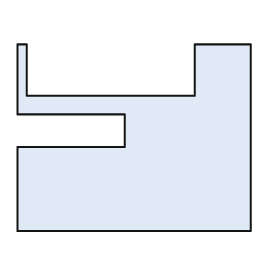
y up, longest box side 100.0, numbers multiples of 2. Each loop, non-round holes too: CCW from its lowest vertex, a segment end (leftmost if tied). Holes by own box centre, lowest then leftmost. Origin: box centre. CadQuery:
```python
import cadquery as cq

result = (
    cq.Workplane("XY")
    .moveTo(-50.0, -40.0)
    .lineTo(50.0, -40.0)
    .lineTo(50.0, 40.0)
    .lineTo(26.0, 40.0)
    .lineTo(26.0, 18.0)
    .lineTo(-46.0, 18.0)
    .lineTo(-46.0, 40.0)
    .lineTo(-50.0, 40.0)
    .lineTo(-50.0, 10.0)
    .lineTo(-4.0, 10.0)
    .lineTo(-4.0, -4.0)
    .lineTo(-50.0, -4.0)
    .close()
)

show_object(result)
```